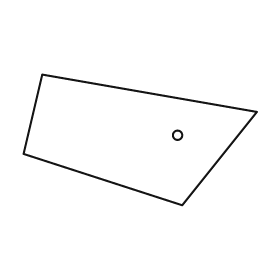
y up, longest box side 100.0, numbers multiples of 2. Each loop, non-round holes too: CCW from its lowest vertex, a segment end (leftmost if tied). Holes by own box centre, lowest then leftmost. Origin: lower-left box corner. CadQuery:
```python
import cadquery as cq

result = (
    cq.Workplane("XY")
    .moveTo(68.0, 0.0)
    .lineTo(100.0, 40.0)
    .lineTo(8.0, 56.0)
    .lineTo(0.0, 22.0)
    .close()
    .moveTo(66.0, 30.0)
    .circle(2.0)
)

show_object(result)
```